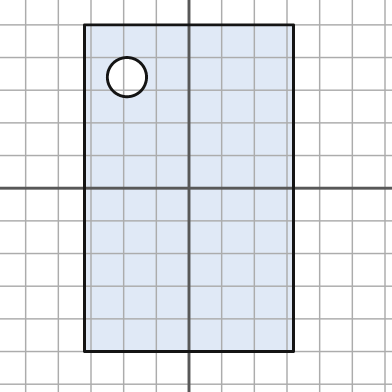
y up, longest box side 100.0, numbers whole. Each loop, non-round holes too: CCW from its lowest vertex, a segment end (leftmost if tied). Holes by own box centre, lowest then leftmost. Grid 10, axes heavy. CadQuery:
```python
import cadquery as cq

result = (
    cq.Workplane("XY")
    .moveTo(-32.0, -50.0)
    .lineTo(32.0, -50.0)
    .lineTo(32.0, 50.0)
    .lineTo(-32.0, 50.0)
    .close()
    .moveTo(-19.0, 34.0)
    .circle(6.0)
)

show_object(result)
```